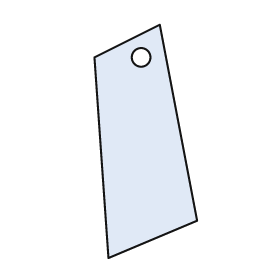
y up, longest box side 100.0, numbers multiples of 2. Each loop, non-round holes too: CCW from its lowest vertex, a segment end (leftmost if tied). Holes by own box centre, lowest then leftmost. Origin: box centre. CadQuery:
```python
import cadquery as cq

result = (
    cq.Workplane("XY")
    .moveTo(-16.0, -50.0)
    .lineTo(22.0, -34.0)
    .lineTo(6.0, 50.0)
    .lineTo(-22.0, 36.0)
    .close()
    .moveTo(-2.0, 36.0)
    .circle(4.0)
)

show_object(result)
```